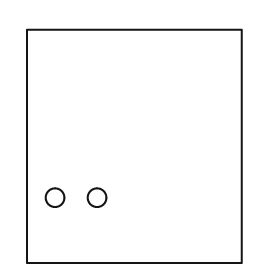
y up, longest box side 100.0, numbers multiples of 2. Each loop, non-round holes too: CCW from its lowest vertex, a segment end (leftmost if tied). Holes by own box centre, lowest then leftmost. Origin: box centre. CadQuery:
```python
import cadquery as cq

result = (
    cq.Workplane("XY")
    .moveTo(-46.0, -50.0)
    .lineTo(46.0, -50.0)
    .lineTo(46.0, 50.0)
    .lineTo(-46.0, 50.0)
    .close()
    .moveTo(-34.0, -22.0)
    .circle(4.0)
    .moveTo(-16.0, -22.0)
    .circle(4.0)
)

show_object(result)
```